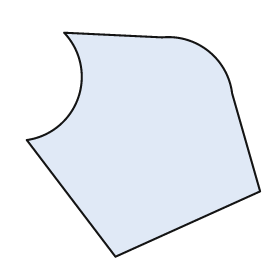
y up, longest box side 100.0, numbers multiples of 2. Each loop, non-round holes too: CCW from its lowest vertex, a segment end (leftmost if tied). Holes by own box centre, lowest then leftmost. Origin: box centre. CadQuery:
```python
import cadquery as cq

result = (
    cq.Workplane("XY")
    .moveTo(-12.0, -48.0)
    .lineTo(50.0, -20.0)
    .lineTo(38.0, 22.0)
    .threePointArc((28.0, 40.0), (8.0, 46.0))
    .lineTo(-34.0, 48.0)
    .threePointArc((-28.0, 20.0), (-50.0, 2.0))
    .close()
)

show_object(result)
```